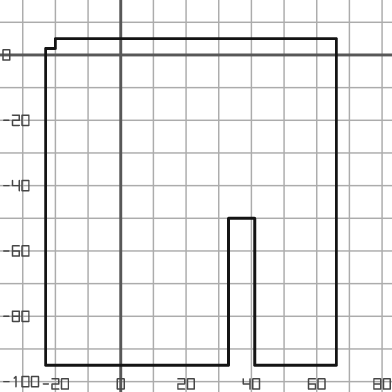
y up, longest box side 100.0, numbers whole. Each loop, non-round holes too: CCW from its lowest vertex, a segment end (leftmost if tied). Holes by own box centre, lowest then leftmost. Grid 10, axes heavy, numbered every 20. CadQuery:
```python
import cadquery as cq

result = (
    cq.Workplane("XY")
    .moveTo(-23.0, -95.0)
    .lineTo(33.0, -95.0)
    .lineTo(33.0, -50.0)
    .lineTo(41.0, -50.0)
    .lineTo(41.0, -95.0)
    .lineTo(66.0, -95.0)
    .lineTo(66.0, 5.0)
    .lineTo(-20.0, 5.0)
    .lineTo(-20.0, 2.0)
    .lineTo(-23.0, 2.0)
    .close()
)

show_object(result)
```